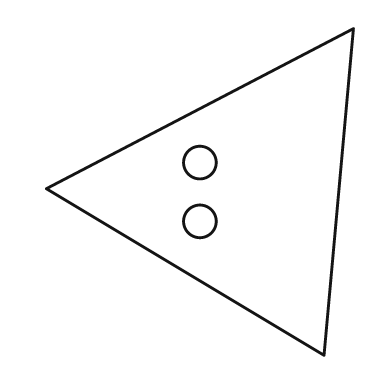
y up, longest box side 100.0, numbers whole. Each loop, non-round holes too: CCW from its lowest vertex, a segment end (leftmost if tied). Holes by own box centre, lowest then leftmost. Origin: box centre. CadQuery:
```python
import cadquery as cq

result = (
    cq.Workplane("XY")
    .moveTo(38.0, -50.0)
    .lineTo(47.0, 50.0)
    .lineTo(-47.0, 1.0)
    .close()
    .moveTo(0.0, -9.0)
    .circle(5.0)
    .moveTo(0.0, 9.0)
    .circle(5.0)
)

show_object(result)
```